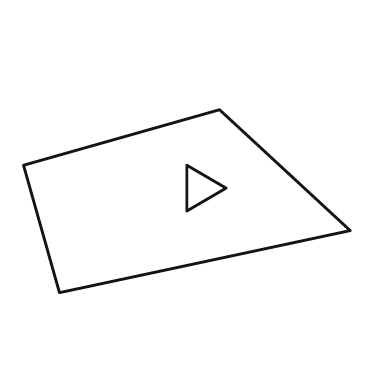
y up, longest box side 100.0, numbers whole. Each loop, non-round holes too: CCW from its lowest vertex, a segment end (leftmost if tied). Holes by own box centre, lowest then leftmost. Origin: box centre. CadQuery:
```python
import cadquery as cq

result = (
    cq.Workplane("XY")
    .moveTo(-39.0, -28.0)
    .lineTo(50.0, -9.0)
    .lineTo(10.0, 28.0)
    .lineTo(-50.0, 11.0)
    .close()
    .moveTo(0.0, -3.0)
    .lineTo(12.0, 4.0)
    .lineTo(0.0, 11.0)
    .close()
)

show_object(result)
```